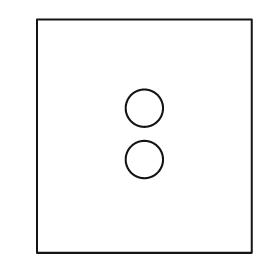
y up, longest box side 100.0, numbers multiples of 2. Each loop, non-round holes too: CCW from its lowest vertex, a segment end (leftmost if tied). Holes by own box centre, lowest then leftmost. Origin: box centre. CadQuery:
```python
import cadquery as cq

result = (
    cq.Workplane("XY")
    .moveTo(-46.0, -50.0)
    .lineTo(46.0, -50.0)
    .lineTo(46.0, 50.0)
    .lineTo(-46.0, 50.0)
    .close()
    .moveTo(0.0, -10.0)
    .circle(8.0)
    .moveTo(0.0, 12.0)
    .circle(8.0)
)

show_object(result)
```